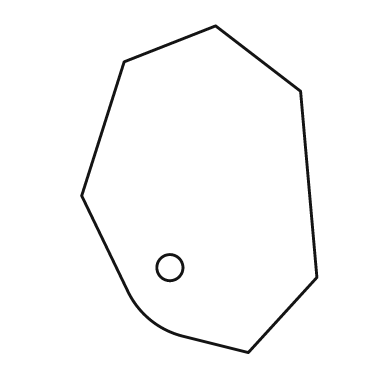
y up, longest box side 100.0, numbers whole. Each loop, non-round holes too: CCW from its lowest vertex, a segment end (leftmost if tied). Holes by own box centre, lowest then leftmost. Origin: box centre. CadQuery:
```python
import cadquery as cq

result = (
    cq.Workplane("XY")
    .moveTo(15.0, -50.0)
    .lineTo(36.0, -27.0)
    .lineTo(31.0, 30.0)
    .lineTo(5.0, 50.0)
    .lineTo(-23.0, 39.0)
    .lineTo(-36.0, -2.0)
    .lineTo(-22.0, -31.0)
    .threePointArc((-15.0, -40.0), (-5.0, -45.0))
    .close()
    .moveTo(-9.0, -24.0)
    .circle(4.0)
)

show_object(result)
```